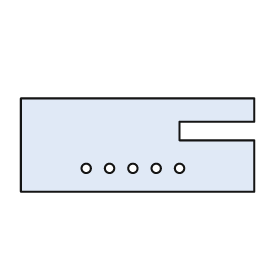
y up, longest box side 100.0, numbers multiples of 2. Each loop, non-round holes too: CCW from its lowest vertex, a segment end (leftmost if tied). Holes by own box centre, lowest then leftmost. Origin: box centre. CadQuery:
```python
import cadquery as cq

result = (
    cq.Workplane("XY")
    .moveTo(-50.0, -20.0)
    .lineTo(50.0, -20.0)
    .lineTo(50.0, 2.0)
    .lineTo(18.0, 2.0)
    .lineTo(18.0, 10.0)
    .lineTo(50.0, 10.0)
    .lineTo(50.0, 20.0)
    .lineTo(-50.0, 20.0)
    .close()
    .moveTo(-22.0, -10.0)
    .circle(2.0)
    .moveTo(-12.0, -10.0)
    .circle(2.0)
    .moveTo(-2.0, -10.0)
    .circle(2.0)
    .moveTo(8.0, -10.0)
    .circle(2.0)
    .moveTo(18.0, -10.0)
    .circle(2.0)
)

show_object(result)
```